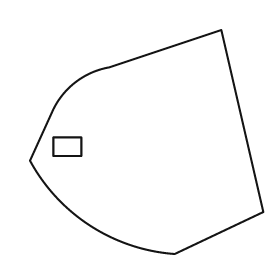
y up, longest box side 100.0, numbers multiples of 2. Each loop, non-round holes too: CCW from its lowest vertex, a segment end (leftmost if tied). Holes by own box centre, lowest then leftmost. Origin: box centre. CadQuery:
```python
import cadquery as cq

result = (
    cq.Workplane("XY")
    .moveTo(12.0, -48.0)
    .lineTo(50.0, -30.0)
    .lineTo(32.0, 48.0)
    .lineTo(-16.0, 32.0)
    .threePointArc((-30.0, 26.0), (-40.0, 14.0))
    .lineTo(-50.0, -8.0)
    .threePointArc((-24.0, -36.0), (12.0, -48.0))
    .close()
    .moveTo(-40.0, -6.0)
    .lineTo(-28.0, -6.0)
    .lineTo(-28.0, 2.0)
    .lineTo(-40.0, 2.0)
    .close()
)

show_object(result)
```